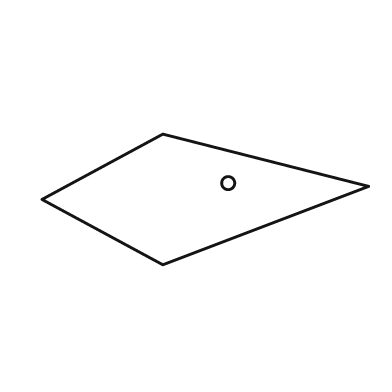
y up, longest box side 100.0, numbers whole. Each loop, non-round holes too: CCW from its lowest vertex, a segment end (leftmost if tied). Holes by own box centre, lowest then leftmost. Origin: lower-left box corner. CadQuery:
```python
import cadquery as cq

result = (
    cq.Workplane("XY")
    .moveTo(37.0, 0.0)
    .lineTo(100.0, 24.0)
    .lineTo(37.0, 40.0)
    .lineTo(0.0, 20.0)
    .close()
    .moveTo(57.0, 25.0)
    .circle(2.0)
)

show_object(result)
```